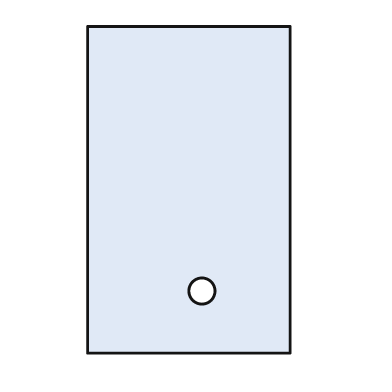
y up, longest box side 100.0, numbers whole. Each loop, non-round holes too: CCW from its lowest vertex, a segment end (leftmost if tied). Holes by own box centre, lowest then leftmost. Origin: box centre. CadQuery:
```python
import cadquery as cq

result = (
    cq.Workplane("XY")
    .moveTo(-31.0, -50.0)
    .lineTo(31.0, -50.0)
    .lineTo(31.0, 50.0)
    .lineTo(-31.0, 50.0)
    .close()
    .moveTo(4.0, -31.0)
    .circle(4.0)
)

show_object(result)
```